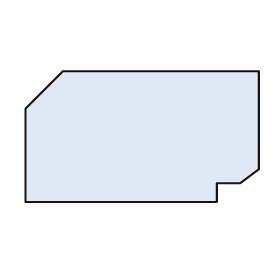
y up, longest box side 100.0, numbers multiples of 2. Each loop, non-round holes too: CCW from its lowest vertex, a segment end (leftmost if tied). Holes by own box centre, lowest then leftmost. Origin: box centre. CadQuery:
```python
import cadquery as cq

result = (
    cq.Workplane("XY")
    .moveTo(-50.0, -28.0)
    .lineTo(32.0, -28.0)
    .lineTo(32.0, -20.0)
    .lineTo(42.0, -20.0)
    .lineTo(50.0, -14.0)
    .lineTo(50.0, 28.0)
    .lineTo(-34.0, 28.0)
    .lineTo(-50.0, 12.0)
    .close()
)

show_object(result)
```